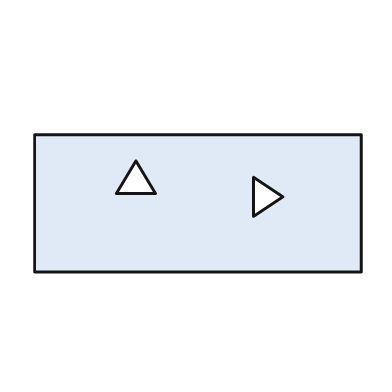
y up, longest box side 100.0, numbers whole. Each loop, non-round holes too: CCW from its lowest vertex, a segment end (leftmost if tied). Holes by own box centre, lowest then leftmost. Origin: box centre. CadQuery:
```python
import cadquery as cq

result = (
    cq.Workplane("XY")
    .moveTo(-50.0, -21.0)
    .lineTo(50.0, -21.0)
    .lineTo(50.0, 21.0)
    .lineTo(-50.0, 21.0)
    .close()
    .moveTo(17.0, -4.0)
    .lineTo(26.0, 2.0)
    .lineTo(17.0, 8.0)
    .close()
    .moveTo(-25.0, 3.0)
    .lineTo(-13.0, 3.0)
    .lineTo(-19.0, 13.0)
    .close()
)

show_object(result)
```